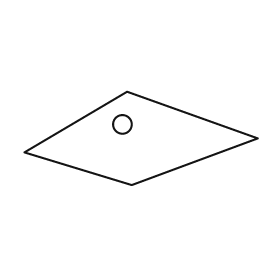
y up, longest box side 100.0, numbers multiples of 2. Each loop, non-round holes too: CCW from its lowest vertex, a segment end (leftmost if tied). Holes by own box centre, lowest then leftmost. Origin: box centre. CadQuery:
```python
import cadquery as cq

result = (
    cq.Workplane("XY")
    .moveTo(-4.0, -20.0)
    .lineTo(50.0, 0.0)
    .lineTo(-6.0, 20.0)
    .lineTo(-50.0, -6.0)
    .close()
    .moveTo(-8.0, 6.0)
    .circle(4.0)
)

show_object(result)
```